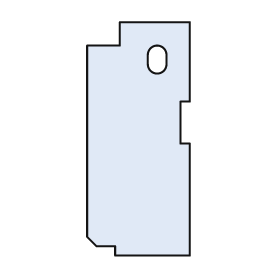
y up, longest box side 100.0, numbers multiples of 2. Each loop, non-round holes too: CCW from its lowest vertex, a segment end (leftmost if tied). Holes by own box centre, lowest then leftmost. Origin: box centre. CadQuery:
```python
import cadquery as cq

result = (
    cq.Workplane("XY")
    .moveTo(-10.0, -50.0)
    .lineTo(22.0, -50.0)
    .lineTo(22.0, -2.0)
    .lineTo(18.0, -2.0)
    .lineTo(18.0, 16.0)
    .lineTo(22.0, 16.0)
    .lineTo(22.0, 50.0)
    .lineTo(-8.0, 50.0)
    .lineTo(-8.0, 40.0)
    .lineTo(-22.0, 40.0)
    .lineTo(-22.0, -42.0)
    .lineTo(-18.0, -46.0)
    .lineTo(-10.0, -46.0)
    .close()
    .moveTo(4.0, 32.0)
    .threePointArc((8.0, 28.0), (12.0, 32.0))
    .lineTo(12.0, 36.0)
    .threePointArc((8.0, 40.0), (4.0, 36.0))
    .close()
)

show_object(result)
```